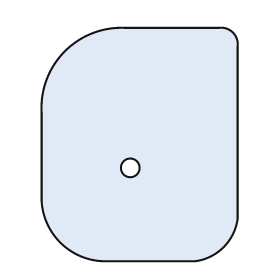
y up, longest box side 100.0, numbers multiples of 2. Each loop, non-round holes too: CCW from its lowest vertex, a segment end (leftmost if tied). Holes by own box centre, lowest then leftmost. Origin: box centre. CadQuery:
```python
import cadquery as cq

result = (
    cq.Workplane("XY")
    .moveTo(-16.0, -50.0)
    .lineTo(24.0, -50.0)
    .threePointArc((36.0, -44.0), (42.0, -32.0))
    .lineTo(42.0, 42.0)
    .threePointArc((40.0, 48.0), (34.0, 50.0))
    .lineTo(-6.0, 50.0)
    .threePointArc((-32.0, 40.0), (-42.0, 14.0))
    .lineTo(-42.0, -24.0)
    .threePointArc((-34.0, -42.0), (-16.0, -50.0))
    .close()
    .moveTo(-4.0, -10.0)
    .circle(4.0)
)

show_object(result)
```